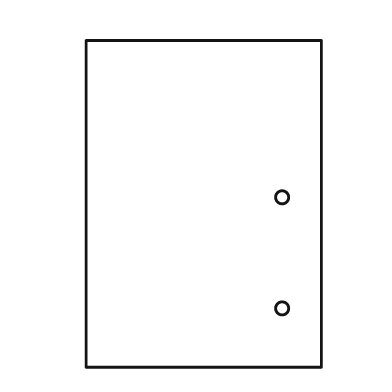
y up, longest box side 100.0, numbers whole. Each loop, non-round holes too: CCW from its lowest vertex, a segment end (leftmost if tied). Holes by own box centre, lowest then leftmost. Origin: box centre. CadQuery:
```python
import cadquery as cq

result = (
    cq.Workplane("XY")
    .moveTo(-36.0, -50.0)
    .lineTo(36.0, -50.0)
    .lineTo(36.0, 50.0)
    .lineTo(-36.0, 50.0)
    .close()
    .moveTo(24.0, -32.0)
    .circle(2.0)
    .moveTo(24.0, 2.0)
    .circle(2.0)
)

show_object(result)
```